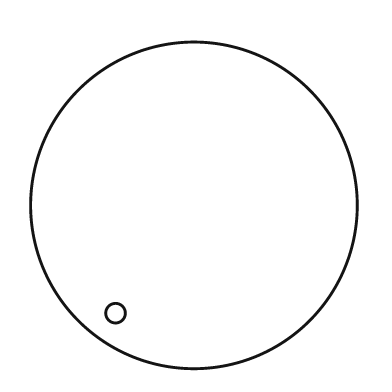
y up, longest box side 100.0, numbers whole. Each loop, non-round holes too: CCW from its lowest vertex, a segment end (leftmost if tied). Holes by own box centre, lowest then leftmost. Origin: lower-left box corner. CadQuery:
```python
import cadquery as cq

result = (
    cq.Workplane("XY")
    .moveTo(50.0, 50.0)
    .circle(50.0)
    .moveTo(26.0, 17.0)
    .circle(3.0)
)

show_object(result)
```